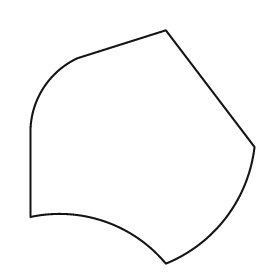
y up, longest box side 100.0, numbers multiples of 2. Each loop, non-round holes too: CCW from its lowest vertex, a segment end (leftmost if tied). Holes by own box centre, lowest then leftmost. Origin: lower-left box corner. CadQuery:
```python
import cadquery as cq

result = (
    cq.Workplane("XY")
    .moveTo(58.0, 0.0)
    .threePointArc((84.0, 20.0), (96.0, 50.0))
    .lineTo(58.0, 100.0)
    .lineTo(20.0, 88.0)
    .threePointArc((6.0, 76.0), (0.0, 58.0))
    .lineTo(0.0, 20.0)
    .threePointArc((32.0, 18.0), (58.0, 0.0))
    .close()
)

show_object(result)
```